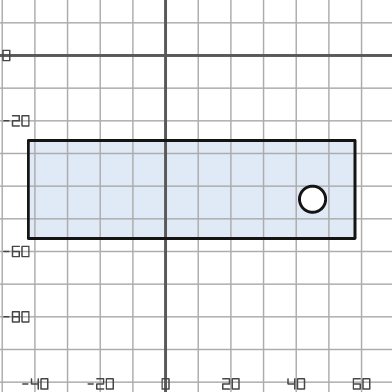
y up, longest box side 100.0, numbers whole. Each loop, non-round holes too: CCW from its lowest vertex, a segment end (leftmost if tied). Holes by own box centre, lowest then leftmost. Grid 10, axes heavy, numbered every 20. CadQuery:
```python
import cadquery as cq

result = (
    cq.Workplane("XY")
    .moveTo(-42.0, -56.0)
    .lineTo(58.0, -56.0)
    .lineTo(58.0, -26.0)
    .lineTo(-42.0, -26.0)
    .close()
    .moveTo(45.0, -44.0)
    .circle(4.0)
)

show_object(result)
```